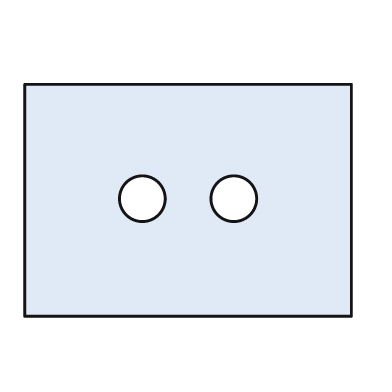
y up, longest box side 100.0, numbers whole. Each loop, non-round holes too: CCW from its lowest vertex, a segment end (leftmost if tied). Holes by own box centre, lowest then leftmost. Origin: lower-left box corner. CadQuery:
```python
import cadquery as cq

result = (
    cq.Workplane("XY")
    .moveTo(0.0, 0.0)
    .lineTo(100.0, 0.0)
    .lineTo(100.0, 71.0)
    .lineTo(0.0, 71.0)
    .close()
    .moveTo(36.0, 36.0)
    .circle(7.0)
    .moveTo(64.0, 36.0)
    .circle(7.0)
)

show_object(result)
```